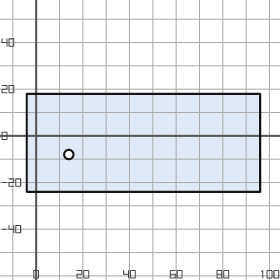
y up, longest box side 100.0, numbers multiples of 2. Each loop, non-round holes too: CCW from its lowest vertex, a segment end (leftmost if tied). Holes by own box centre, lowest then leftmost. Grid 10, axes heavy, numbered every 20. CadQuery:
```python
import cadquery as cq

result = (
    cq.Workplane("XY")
    .moveTo(-4.0, -24.0)
    .lineTo(96.0, -24.0)
    .lineTo(96.0, 18.0)
    .lineTo(-4.0, 18.0)
    .close()
    .moveTo(14.0, -8.0)
    .circle(2.0)
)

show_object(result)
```